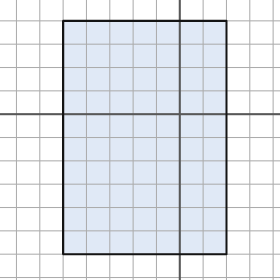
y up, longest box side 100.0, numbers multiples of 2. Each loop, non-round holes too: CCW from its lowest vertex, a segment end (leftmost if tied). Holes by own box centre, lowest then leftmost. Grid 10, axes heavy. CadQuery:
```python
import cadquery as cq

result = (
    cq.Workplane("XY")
    .moveTo(-50.0, -60.0)
    .lineTo(20.0, -60.0)
    .lineTo(20.0, 40.0)
    .lineTo(-50.0, 40.0)
    .close()
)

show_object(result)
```